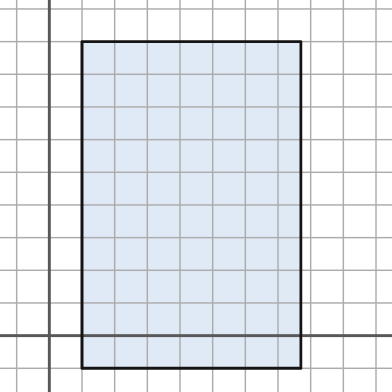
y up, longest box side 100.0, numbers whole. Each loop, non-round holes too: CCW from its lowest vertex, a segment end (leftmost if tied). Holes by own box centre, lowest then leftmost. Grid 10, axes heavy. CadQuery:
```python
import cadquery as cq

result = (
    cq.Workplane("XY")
    .moveTo(10.0, -10.0)
    .lineTo(77.0, -10.0)
    .lineTo(77.0, 90.0)
    .lineTo(10.0, 90.0)
    .close()
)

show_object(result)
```